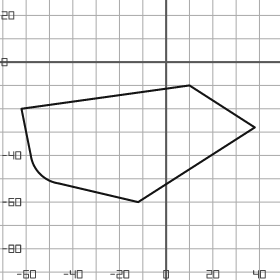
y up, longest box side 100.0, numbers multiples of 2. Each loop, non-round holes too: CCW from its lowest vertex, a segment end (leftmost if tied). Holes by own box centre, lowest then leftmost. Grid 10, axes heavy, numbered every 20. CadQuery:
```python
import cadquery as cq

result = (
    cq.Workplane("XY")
    .moveTo(-12.0, -60.0)
    .lineTo(38.0, -28.0)
    .lineTo(10.0, -10.0)
    .lineTo(-62.0, -20.0)
    .lineTo(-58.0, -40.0)
    .threePointArc((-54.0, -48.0), (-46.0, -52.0))
    .close()
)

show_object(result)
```